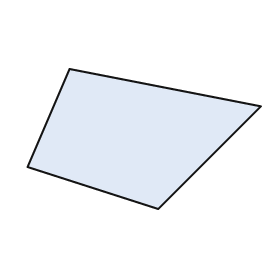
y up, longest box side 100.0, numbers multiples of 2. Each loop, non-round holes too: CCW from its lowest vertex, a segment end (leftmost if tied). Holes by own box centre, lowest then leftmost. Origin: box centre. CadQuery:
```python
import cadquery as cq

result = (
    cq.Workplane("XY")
    .moveTo(6.0, -30.0)
    .lineTo(50.0, 14.0)
    .lineTo(-32.0, 30.0)
    .lineTo(-50.0, -12.0)
    .close()
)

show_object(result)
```